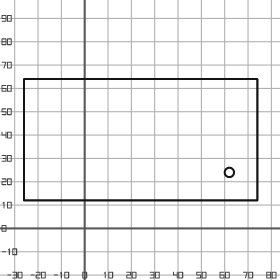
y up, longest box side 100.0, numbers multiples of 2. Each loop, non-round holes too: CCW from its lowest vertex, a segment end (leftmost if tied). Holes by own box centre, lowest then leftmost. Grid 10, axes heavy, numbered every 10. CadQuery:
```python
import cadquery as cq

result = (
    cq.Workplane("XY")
    .moveTo(-26.0, 12.0)
    .lineTo(74.0, 12.0)
    .lineTo(74.0, 64.0)
    .lineTo(-26.0, 64.0)
    .close()
    .moveTo(62.0, 24.0)
    .circle(2.0)
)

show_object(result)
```